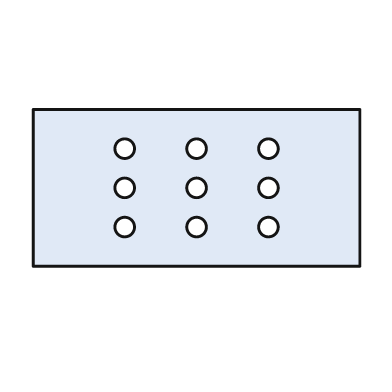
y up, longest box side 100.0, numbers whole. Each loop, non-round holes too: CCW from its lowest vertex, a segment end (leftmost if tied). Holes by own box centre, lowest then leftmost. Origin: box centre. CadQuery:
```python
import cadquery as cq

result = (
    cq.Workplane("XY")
    .moveTo(-50.0, -24.0)
    .lineTo(50.0, -24.0)
    .lineTo(50.0, 24.0)
    .lineTo(-50.0, 24.0)
    .close()
    .moveTo(-22.0, -12.0)
    .circle(3.0)
    .moveTo(0.0, -12.0)
    .circle(3.0)
    .moveTo(22.0, -12.0)
    .circle(3.0)
    .moveTo(-22.0, 0.0)
    .circle(3.0)
    .moveTo(0.0, 0.0)
    .circle(3.0)
    .moveTo(22.0, 0.0)
    .circle(3.0)
    .moveTo(-22.0, 12.0)
    .circle(3.0)
    .moveTo(0.0, 12.0)
    .circle(3.0)
    .moveTo(22.0, 12.0)
    .circle(3.0)
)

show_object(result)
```